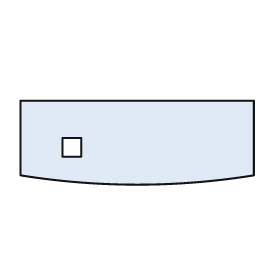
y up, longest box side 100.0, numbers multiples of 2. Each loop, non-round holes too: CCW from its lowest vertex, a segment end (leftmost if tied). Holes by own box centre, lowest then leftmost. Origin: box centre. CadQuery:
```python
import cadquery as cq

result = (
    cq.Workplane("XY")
    .moveTo(-50.0, -14.0)
    .threePointArc((0.0, -18.0), (50.0, -14.0))
    .lineTo(50.0, 18.0)
    .lineTo(-50.0, 18.0)
    .close()
    .moveTo(-32.0, -6.0)
    .lineTo(-24.0, -6.0)
    .lineTo(-24.0, 2.0)
    .lineTo(-32.0, 2.0)
    .close()
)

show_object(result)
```